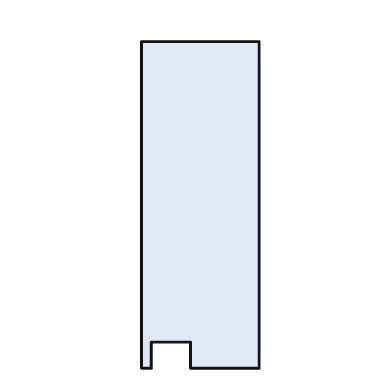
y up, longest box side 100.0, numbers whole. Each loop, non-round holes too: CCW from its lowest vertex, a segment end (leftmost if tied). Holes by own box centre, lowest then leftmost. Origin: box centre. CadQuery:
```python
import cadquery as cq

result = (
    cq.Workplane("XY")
    .moveTo(-18.0, -50.0)
    .lineTo(-15.0, -50.0)
    .lineTo(-15.0, -42.0)
    .lineTo(-3.0, -42.0)
    .lineTo(-3.0, -50.0)
    .lineTo(18.0, -50.0)
    .lineTo(18.0, 50.0)
    .lineTo(-18.0, 50.0)
    .close()
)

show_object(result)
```